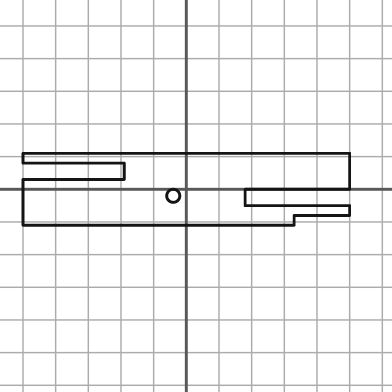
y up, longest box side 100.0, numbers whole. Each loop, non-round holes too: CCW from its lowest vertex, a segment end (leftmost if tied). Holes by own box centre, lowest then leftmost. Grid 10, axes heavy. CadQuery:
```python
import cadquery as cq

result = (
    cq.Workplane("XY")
    .moveTo(-50.0, -11.0)
    .lineTo(33.0, -11.0)
    .lineTo(33.0, -8.0)
    .lineTo(50.0, -8.0)
    .lineTo(50.0, -5.0)
    .lineTo(18.0, -5.0)
    .lineTo(18.0, 0.0)
    .lineTo(50.0, 0.0)
    .lineTo(50.0, 11.0)
    .lineTo(-50.0, 11.0)
    .lineTo(-50.0, 8.0)
    .lineTo(-19.0, 8.0)
    .lineTo(-19.0, 3.0)
    .lineTo(-50.0, 3.0)
    .close()
    .moveTo(-4.0, -2.0)
    .circle(2.0)
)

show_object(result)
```